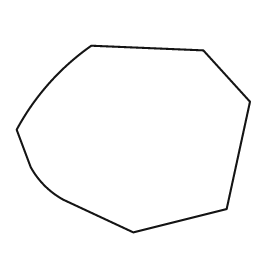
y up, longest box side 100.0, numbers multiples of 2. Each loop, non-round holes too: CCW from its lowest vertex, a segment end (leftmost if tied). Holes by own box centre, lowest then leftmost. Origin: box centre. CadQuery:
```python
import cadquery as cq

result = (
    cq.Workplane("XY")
    .moveTo(0.0, -40.0)
    .lineTo(40.0, -30.0)
    .lineTo(50.0, 16.0)
    .lineTo(30.0, 38.0)
    .lineTo(-18.0, 40.0)
    .threePointArc((-36.0, 24.0), (-50.0, 4.0))
    .lineTo(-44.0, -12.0)
    .threePointArc((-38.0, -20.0), (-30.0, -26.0))
    .close()
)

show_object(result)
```